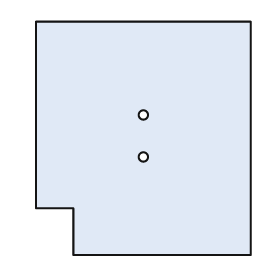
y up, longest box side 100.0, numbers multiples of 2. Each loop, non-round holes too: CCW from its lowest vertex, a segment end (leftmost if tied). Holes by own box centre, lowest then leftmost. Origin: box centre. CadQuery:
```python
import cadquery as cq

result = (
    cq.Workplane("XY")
    .moveTo(-30.0, -50.0)
    .lineTo(46.0, -50.0)
    .lineTo(46.0, 50.0)
    .lineTo(-46.0, 50.0)
    .lineTo(-46.0, -30.0)
    .lineTo(-30.0, -30.0)
    .close()
    .moveTo(0.0, -8.0)
    .circle(2.0)
    .moveTo(0.0, 10.0)
    .circle(2.0)
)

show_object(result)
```